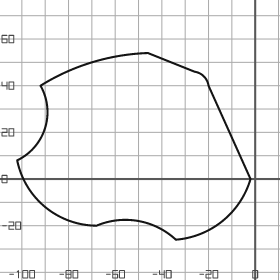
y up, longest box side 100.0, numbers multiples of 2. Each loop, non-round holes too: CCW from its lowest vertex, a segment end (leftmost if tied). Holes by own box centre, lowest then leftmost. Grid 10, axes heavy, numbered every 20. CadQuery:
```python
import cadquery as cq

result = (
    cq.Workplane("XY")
    .moveTo(-34.0, -26.0)
    .threePointArc((-14.0, -18.0), (-2.0, 0.0))
    .lineTo(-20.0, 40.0)
    .threePointArc((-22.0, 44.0), (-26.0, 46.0))
    .lineTo(-46.0, 54.0)
    .threePointArc((-70.0, 50.0), (-92.0, 40.0))
    .threePointArc((-90.0, 22.0), (-102.0, 8.0))
    .threePointArc((-90.0, -12.0), (-68.0, -20.0))
    .threePointArc((-50.0, -18.0), (-34.0, -26.0))
    .close()
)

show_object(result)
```